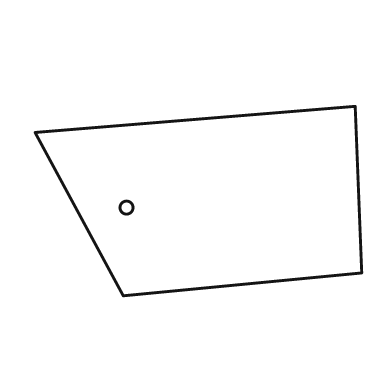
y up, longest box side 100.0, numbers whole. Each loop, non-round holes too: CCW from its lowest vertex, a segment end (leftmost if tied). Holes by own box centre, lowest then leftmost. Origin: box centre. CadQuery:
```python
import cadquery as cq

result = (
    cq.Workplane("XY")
    .moveTo(-23.0, -29.0)
    .lineTo(50.0, -22.0)
    .lineTo(48.0, 29.0)
    .lineTo(-50.0, 21.0)
    .close()
    .moveTo(-22.0, -2.0)
    .circle(2.0)
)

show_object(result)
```